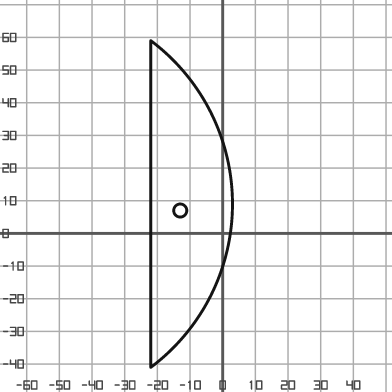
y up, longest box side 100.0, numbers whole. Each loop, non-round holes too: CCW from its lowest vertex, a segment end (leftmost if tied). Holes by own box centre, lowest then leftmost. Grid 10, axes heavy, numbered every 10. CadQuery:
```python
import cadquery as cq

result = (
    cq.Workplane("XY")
    .moveTo(-22.0, -41.0)
    .threePointArc((3.0, 9.0), (-22.0, 59.0))
    .close()
    .moveTo(-13.0, 7.0)
    .circle(2.0)
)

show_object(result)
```